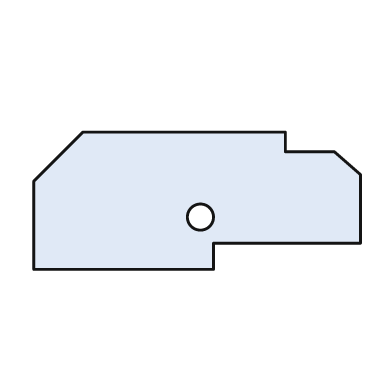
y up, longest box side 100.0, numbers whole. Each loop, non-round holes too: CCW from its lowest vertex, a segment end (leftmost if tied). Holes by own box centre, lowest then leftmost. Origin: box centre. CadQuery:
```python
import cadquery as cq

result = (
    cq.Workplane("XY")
    .moveTo(-50.0, -21.0)
    .lineTo(5.0, -21.0)
    .lineTo(5.0, -13.0)
    .lineTo(50.0, -13.0)
    .lineTo(50.0, 8.0)
    .lineTo(42.0, 15.0)
    .lineTo(27.0, 15.0)
    .lineTo(27.0, 21.0)
    .lineTo(-35.0, 21.0)
    .lineTo(-50.0, 6.0)
    .close()
    .moveTo(1.0, -5.0)
    .circle(4.0)
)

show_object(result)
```